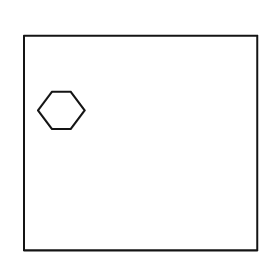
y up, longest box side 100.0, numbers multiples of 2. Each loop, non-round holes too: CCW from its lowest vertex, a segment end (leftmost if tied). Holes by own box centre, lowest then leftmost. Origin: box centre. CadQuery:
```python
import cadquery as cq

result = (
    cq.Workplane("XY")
    .moveTo(-50.0, -46.0)
    .lineTo(50.0, -46.0)
    .lineTo(50.0, 46.0)
    .lineTo(-50.0, 46.0)
    .close()
    .moveTo(-38.0, 6.0)
    .lineTo(-30.0, 6.0)
    .lineTo(-24.0, 14.0)
    .lineTo(-30.0, 22.0)
    .lineTo(-38.0, 22.0)
    .lineTo(-44.0, 14.0)
    .close()
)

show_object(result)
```